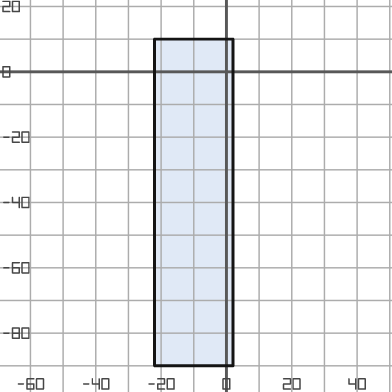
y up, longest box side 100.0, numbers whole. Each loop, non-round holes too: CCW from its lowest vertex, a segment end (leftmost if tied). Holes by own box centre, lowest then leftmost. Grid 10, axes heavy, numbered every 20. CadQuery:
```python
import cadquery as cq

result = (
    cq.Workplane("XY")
    .moveTo(-22.0, -90.0)
    .lineTo(2.0, -90.0)
    .lineTo(2.0, 10.0)
    .lineTo(-22.0, 10.0)
    .close()
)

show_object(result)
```